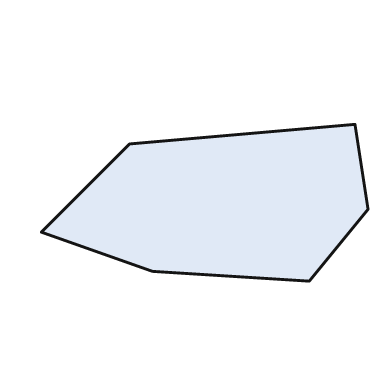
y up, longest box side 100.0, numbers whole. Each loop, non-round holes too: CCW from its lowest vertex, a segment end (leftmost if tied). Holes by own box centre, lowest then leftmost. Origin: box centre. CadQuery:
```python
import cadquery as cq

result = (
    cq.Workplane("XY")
    .moveTo(32.0, -24.0)
    .lineTo(50.0, -2.0)
    .lineTo(46.0, 24.0)
    .lineTo(-23.0, 18.0)
    .lineTo(-50.0, -9.0)
    .lineTo(-16.0, -21.0)
    .close()
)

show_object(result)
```